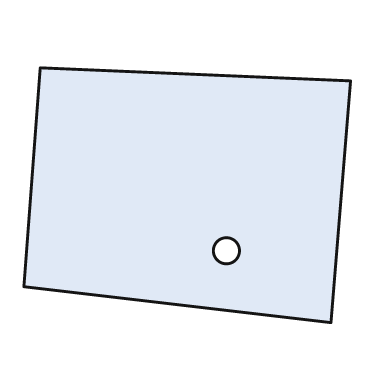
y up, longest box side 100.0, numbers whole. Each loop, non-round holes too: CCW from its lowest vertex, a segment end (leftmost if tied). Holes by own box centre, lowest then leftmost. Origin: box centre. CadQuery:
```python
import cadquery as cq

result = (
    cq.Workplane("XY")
    .moveTo(44.0, -39.0)
    .lineTo(50.0, 35.0)
    .lineTo(-45.0, 39.0)
    .lineTo(-50.0, -28.0)
    .close()
    .moveTo(12.0, -17.0)
    .circle(4.0)
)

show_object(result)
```